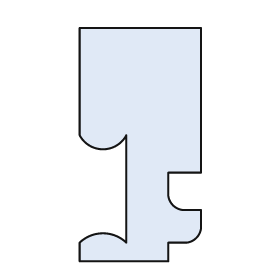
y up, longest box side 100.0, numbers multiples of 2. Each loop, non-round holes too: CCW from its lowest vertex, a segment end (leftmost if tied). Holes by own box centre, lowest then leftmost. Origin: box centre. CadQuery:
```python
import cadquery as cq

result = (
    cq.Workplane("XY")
    .moveTo(-26.0, -50.0)
    .lineTo(12.0, -50.0)
    .lineTo(12.0, -42.0)
    .lineTo(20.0, -42.0)
    .threePointArc((24.0, -40.0), (26.0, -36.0))
    .lineTo(26.0, -28.0)
    .lineTo(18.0, -28.0)
    .threePointArc((14.0, -26.0), (12.0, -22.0))
    .lineTo(12.0, -12.0)
    .lineTo(26.0, -12.0)
    .lineTo(26.0, 50.0)
    .lineTo(-26.0, 50.0)
    .lineTo(-26.0, 4.0)
    .threePointArc((-16.0, -2.0), (-6.0, 4.0))
    .lineTo(-6.0, -42.0)
    .threePointArc((-16.0, -38.0), (-26.0, -42.0))
    .close()
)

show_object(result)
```